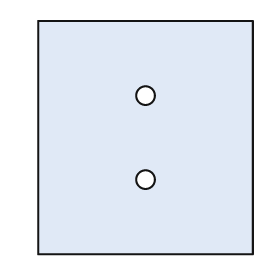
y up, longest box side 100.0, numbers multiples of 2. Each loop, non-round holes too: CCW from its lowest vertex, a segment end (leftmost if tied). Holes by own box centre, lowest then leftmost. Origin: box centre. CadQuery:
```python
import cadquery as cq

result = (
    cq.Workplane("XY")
    .moveTo(-46.0, -50.0)
    .lineTo(46.0, -50.0)
    .lineTo(46.0, 50.0)
    .lineTo(-46.0, 50.0)
    .close()
    .moveTo(0.0, -18.0)
    .circle(4.0)
    .moveTo(0.0, 18.0)
    .circle(4.0)
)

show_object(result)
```